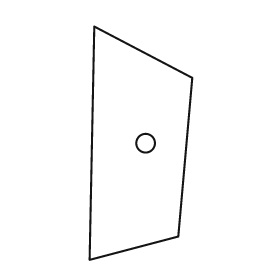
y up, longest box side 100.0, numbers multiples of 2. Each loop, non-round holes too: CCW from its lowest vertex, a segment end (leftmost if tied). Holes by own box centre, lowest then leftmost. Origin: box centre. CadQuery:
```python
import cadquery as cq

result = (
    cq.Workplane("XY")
    .moveTo(-22.0, -50.0)
    .lineTo(16.0, -40.0)
    .lineTo(22.0, 28.0)
    .lineTo(-20.0, 50.0)
    .close()
    .moveTo(2.0, 0.0)
    .circle(4.0)
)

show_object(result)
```